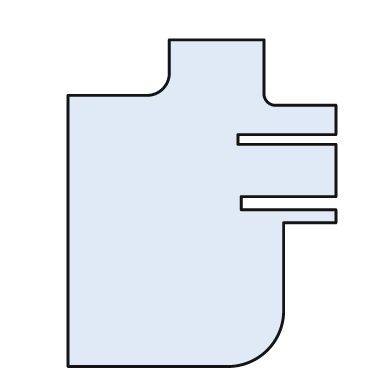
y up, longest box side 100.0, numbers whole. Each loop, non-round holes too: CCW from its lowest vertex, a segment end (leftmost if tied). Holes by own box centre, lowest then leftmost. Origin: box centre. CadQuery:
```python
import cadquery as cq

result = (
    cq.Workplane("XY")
    .moveTo(-41.0, -50.0)
    .lineTo(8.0, -50.0)
    .threePointArc((20.0, -45.0), (25.0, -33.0))
    .lineTo(25.0, -6.0)
    .lineTo(41.0, -6.0)
    .lineTo(41.0, -2.0)
    .lineTo(12.0, -2.0)
    .lineTo(12.0, 2.0)
    .lineTo(41.0, 2.0)
    .lineTo(41.0, 18.0)
    .lineTo(11.0, 18.0)
    .lineTo(11.0, 21.0)
    .lineTo(41.0, 21.0)
    .lineTo(41.0, 30.0)
    .lineTo(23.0, 30.0)
    .threePointArc((20.0, 31.0), (19.0, 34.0))
    .lineTo(19.0, 50.0)
    .lineTo(-10.0, 50.0)
    .lineTo(-10.0, 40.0)
    .threePointArc((-12.0, 35.0), (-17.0, 33.0))
    .lineTo(-41.0, 33.0)
    .close()
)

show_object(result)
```